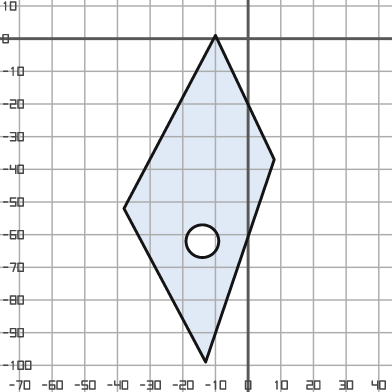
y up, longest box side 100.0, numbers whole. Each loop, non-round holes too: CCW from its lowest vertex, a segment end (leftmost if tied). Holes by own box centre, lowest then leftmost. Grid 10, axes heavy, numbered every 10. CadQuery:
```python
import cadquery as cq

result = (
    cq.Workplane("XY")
    .moveTo(-13.0, -99.0)
    .lineTo(8.0, -37.0)
    .lineTo(-10.0, 1.0)
    .lineTo(-38.0, -52.0)
    .close()
    .moveTo(-14.0, -62.0)
    .circle(5.0)
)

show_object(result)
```